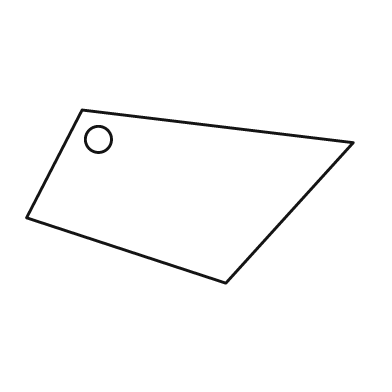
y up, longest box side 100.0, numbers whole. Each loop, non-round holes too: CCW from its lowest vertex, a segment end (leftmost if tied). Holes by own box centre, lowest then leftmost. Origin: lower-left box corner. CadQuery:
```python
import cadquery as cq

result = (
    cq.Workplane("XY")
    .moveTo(61.0, 0.0)
    .lineTo(100.0, 43.0)
    .lineTo(17.0, 53.0)
    .lineTo(0.0, 20.0)
    .close()
    .moveTo(22.0, 44.0)
    .circle(4.0)
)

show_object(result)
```